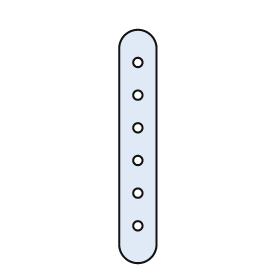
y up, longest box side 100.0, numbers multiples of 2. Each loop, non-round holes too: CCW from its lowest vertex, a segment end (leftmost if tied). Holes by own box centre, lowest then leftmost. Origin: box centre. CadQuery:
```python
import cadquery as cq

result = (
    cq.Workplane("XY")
    .moveTo(-8.0, -42.0)
    .threePointArc((0.0, -50.0), (8.0, -42.0))
    .lineTo(8.0, 42.0)
    .threePointArc((0.0, 50.0), (-8.0, 42.0))
    .close()
    .moveTo(0.0, -34.0)
    .circle(2.0)
    .moveTo(0.0, -20.0)
    .circle(2.0)
    .moveTo(0.0, -6.0)
    .circle(2.0)
    .moveTo(0.0, 8.0)
    .circle(2.0)
    .moveTo(0.0, 22.0)
    .circle(2.0)
    .moveTo(0.0, 36.0)
    .circle(2.0)
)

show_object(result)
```